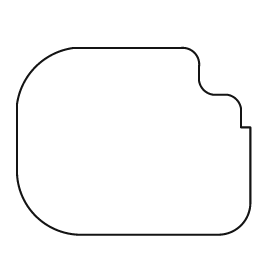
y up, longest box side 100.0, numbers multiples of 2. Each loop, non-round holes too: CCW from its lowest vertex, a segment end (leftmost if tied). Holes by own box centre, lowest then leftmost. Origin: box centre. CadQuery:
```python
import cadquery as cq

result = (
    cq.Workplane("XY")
    .moveTo(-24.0, -40.0)
    .lineTo(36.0, -40.0)
    .threePointArc((46.0, -36.0), (50.0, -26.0))
    .lineTo(50.0, 6.0)
    .lineTo(46.0, 6.0)
    .lineTo(46.0, 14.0)
    .threePointArc((44.0, 18.0), (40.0, 20.0))
    .lineTo(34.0, 20.0)
    .threePointArc((30.0, 22.0), (28.0, 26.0))
    .lineTo(28.0, 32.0)
    .threePointArc((26.0, 38.0), (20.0, 40.0))
    .lineTo(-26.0, 40.0)
    .threePointArc((-42.0, 32.0), (-50.0, 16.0))
    .lineTo(-50.0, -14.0)
    .threePointArc((-42.0, -32.0), (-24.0, -40.0))
    .close()
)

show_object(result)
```